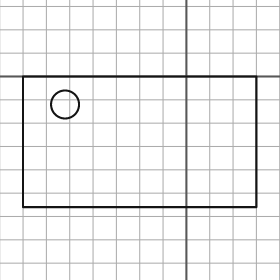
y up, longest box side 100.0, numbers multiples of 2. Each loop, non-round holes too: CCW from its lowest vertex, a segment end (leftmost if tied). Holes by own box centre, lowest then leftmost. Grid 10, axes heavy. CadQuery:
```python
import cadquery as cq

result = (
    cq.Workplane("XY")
    .moveTo(-70.0, -56.0)
    .lineTo(30.0, -56.0)
    .lineTo(30.0, 0.0)
    .lineTo(-70.0, 0.0)
    .close()
    .moveTo(-52.0, -12.0)
    .circle(6.0)
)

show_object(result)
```